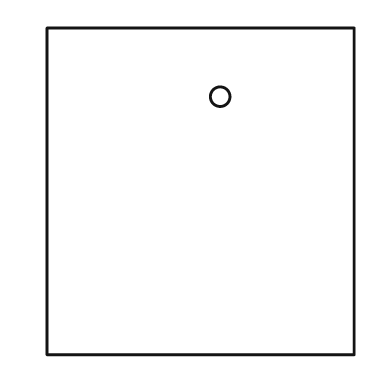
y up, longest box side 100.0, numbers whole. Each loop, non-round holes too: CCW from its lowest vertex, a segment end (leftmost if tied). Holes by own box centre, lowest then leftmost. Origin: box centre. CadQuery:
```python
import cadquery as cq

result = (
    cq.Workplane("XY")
    .moveTo(-47.0, -50.0)
    .lineTo(47.0, -50.0)
    .lineTo(47.0, 50.0)
    .lineTo(-47.0, 50.0)
    .close()
    .moveTo(6.0, 29.0)
    .circle(3.0)
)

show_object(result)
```